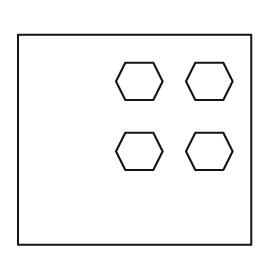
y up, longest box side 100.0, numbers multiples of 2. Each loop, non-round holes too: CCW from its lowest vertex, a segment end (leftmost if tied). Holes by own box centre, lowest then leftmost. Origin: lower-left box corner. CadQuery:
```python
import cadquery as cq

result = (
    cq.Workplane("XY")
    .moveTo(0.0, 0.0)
    .lineTo(100.0, 0.0)
    .lineTo(100.0, 90.0)
    .lineTo(0.0, 90.0)
    .close()
    .moveTo(46.0, 32.0)
    .lineTo(58.0, 32.0)
    .lineTo(62.0, 40.0)
    .lineTo(58.0, 48.0)
    .lineTo(46.0, 48.0)
    .lineTo(42.0, 40.0)
    .close()
    .moveTo(76.0, 32.0)
    .lineTo(88.0, 32.0)
    .lineTo(92.0, 40.0)
    .lineTo(88.0, 48.0)
    .lineTo(76.0, 48.0)
    .lineTo(72.0, 40.0)
    .close()
    .moveTo(46.0, 62.0)
    .lineTo(58.0, 62.0)
    .lineTo(62.0, 70.0)
    .lineTo(58.0, 78.0)
    .lineTo(46.0, 78.0)
    .lineTo(42.0, 70.0)
    .close()
    .moveTo(76.0, 62.0)
    .lineTo(88.0, 62.0)
    .lineTo(92.0, 70.0)
    .lineTo(88.0, 78.0)
    .lineTo(76.0, 78.0)
    .lineTo(72.0, 70.0)
    .close()
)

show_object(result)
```